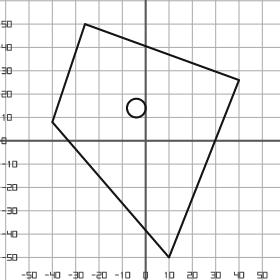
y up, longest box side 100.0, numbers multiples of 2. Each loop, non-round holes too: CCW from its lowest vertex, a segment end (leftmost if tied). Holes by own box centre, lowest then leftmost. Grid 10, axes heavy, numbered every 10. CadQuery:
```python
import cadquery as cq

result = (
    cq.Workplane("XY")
    .moveTo(10.0, -50.0)
    .lineTo(40.0, 26.0)
    .lineTo(-26.0, 50.0)
    .lineTo(-40.0, 8.0)
    .close()
    .moveTo(-4.0, 14.0)
    .circle(4.0)
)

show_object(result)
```